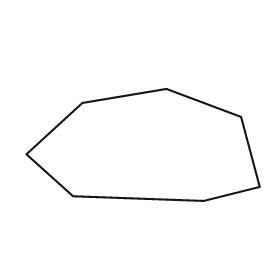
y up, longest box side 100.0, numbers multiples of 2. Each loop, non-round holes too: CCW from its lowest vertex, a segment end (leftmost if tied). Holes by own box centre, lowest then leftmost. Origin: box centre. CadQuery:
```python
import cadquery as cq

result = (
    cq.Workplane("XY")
    .moveTo(26.0, -24.0)
    .lineTo(50.0, -18.0)
    .lineTo(42.0, 12.0)
    .lineTo(10.0, 24.0)
    .lineTo(-26.0, 18.0)
    .lineTo(-50.0, -4.0)
    .lineTo(-30.0, -22.0)
    .close()
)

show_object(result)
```